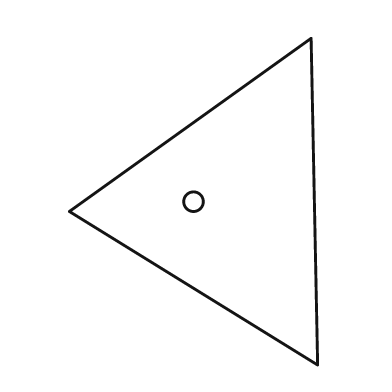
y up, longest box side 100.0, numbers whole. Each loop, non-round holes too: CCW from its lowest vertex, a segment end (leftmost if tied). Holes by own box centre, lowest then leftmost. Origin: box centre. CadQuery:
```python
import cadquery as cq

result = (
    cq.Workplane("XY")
    .moveTo(38.0, -50.0)
    .lineTo(36.0, 50.0)
    .lineTo(-38.0, -3.0)
    .close()
    .moveTo(0.0, 0.0)
    .circle(3.0)
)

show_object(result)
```